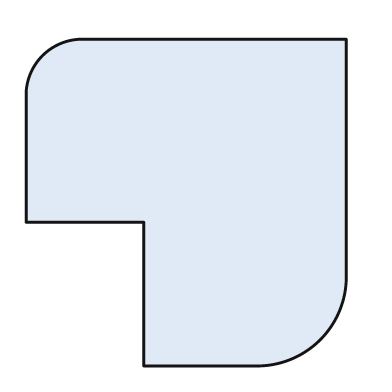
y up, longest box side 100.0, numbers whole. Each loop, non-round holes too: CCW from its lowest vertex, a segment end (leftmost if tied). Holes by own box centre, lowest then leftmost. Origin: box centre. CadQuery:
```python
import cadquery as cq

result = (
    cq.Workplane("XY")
    .moveTo(-13.0, -50.0)
    .lineTo(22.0, -50.0)
    .threePointArc((41.0, -42.0), (49.0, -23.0))
    .lineTo(49.0, 50.0)
    .lineTo(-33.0, 50.0)
    .threePointArc((-44.0, 45.0), (-49.0, 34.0))
    .lineTo(-49.0, -6.0)
    .lineTo(-13.0, -6.0)
    .close()
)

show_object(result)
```